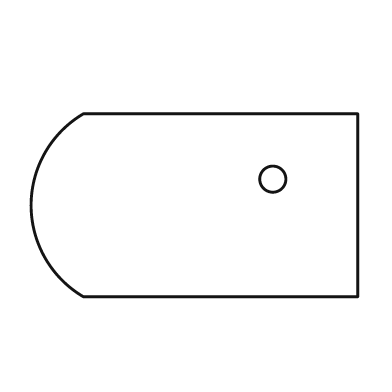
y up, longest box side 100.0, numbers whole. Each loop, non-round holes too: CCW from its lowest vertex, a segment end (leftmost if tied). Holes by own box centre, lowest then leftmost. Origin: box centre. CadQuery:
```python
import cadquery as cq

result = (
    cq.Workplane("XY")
    .moveTo(-34.0, -28.0)
    .lineTo(50.0, -28.0)
    .lineTo(50.0, 28.0)
    .lineTo(-34.0, 28.0)
    .threePointArc((-50.0, 0.0), (-34.0, -28.0))
    .close()
    .moveTo(24.0, 8.0)
    .circle(4.0)
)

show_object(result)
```